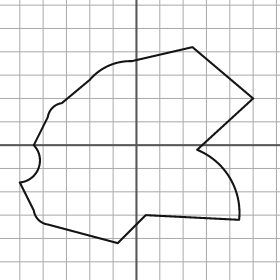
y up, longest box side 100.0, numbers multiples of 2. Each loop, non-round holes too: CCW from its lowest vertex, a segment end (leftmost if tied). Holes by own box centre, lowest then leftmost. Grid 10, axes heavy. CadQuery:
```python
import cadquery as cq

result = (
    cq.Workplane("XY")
    .moveTo(-8.0, -42.0)
    .lineTo(4.0, -30.0)
    .lineTo(44.0, -32.0)
    .threePointArc((40.0, -14.0), (26.0, -2.0))
    .lineTo(50.0, 20.0)
    .lineTo(24.0, 42.0)
    .lineTo(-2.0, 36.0)
    .threePointArc((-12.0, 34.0), (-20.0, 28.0))
    .lineTo(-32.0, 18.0)
    .threePointArc((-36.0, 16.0), (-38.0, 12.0))
    .lineTo(-44.0, 0.0)
    .threePointArc((-42.0, -10.0), (-50.0, -16.0))
    .lineTo(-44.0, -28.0)
    .threePointArc((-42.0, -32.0), (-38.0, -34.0))
    .close()
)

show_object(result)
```